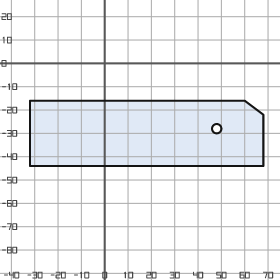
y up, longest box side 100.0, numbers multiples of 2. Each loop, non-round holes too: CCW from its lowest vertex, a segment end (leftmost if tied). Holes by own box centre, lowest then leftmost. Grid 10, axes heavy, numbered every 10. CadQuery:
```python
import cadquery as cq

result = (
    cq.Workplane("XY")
    .moveTo(-32.0, -44.0)
    .lineTo(68.0, -44.0)
    .lineTo(68.0, -22.0)
    .lineTo(60.0, -16.0)
    .lineTo(-32.0, -16.0)
    .close()
    .moveTo(48.0, -28.0)
    .circle(2.0)
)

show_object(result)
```